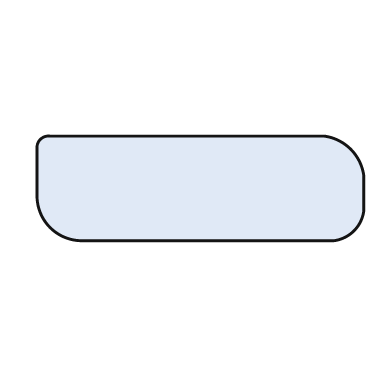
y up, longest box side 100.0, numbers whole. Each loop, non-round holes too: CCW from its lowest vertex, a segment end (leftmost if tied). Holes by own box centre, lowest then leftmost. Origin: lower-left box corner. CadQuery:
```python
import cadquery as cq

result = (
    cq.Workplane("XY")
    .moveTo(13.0, 0.0)
    .lineTo(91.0, 0.0)
    .threePointArc((97.0, 3.0), (100.0, 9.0))
    .lineTo(100.0, 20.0)
    .threePointArc((96.0, 28.0), (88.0, 32.0))
    .lineTo(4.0, 32.0)
    .threePointArc((1.0, 31.0), (0.0, 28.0))
    .lineTo(0.0, 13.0)
    .threePointArc((4.0, 4.0), (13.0, 0.0))
    .close()
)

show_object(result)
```